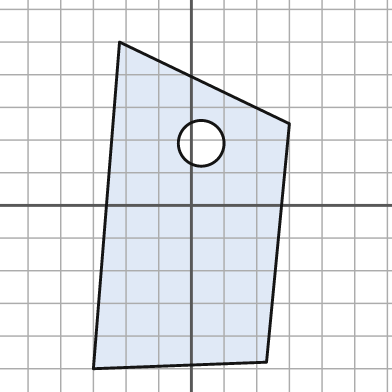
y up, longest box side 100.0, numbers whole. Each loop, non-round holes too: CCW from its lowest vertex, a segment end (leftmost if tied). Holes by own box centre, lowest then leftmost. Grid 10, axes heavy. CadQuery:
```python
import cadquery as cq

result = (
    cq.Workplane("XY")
    .moveTo(-30.0, -50.0)
    .lineTo(23.0, -48.0)
    .lineTo(30.0, 25.0)
    .lineTo(-22.0, 50.0)
    .close()
    .moveTo(3.0, 19.0)
    .circle(7.0)
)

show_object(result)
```